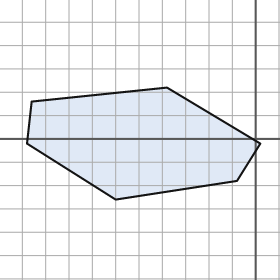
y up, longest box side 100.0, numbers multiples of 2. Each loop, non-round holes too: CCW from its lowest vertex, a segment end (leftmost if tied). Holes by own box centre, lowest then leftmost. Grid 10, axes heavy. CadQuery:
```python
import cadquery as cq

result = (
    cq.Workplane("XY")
    .moveTo(-60.0, -26.0)
    .lineTo(-8.0, -18.0)
    .lineTo(2.0, -2.0)
    .lineTo(-38.0, 22.0)
    .lineTo(-96.0, 16.0)
    .lineTo(-98.0, -2.0)
    .close()
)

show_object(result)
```